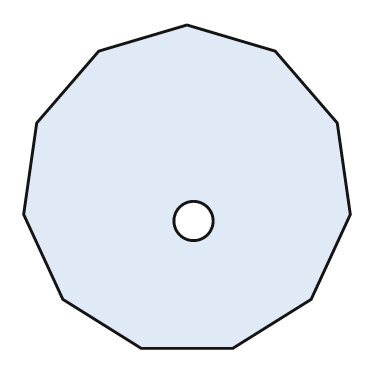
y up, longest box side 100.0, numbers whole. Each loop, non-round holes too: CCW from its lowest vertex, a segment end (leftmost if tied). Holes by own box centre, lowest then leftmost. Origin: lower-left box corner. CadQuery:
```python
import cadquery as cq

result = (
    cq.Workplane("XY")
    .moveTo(36.0, 0.0)
    .lineTo(64.0, 0.0)
    .lineTo(88.0, 15.0)
    .lineTo(100.0, 41.0)
    .lineTo(96.0, 69.0)
    .lineTo(77.0, 91.0)
    .lineTo(50.0, 99.0)
    .lineTo(23.0, 91.0)
    .lineTo(4.0, 69.0)
    .lineTo(0.0, 41.0)
    .lineTo(12.0, 15.0)
    .close()
    .moveTo(52.0, 39.0)
    .circle(6.0)
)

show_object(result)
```